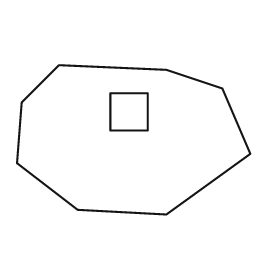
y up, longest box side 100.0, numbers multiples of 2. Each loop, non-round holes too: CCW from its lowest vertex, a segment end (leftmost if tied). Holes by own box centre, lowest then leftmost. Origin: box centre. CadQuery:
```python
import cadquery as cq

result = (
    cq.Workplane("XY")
    .moveTo(14.0, -32.0)
    .lineTo(50.0, -6.0)
    .lineTo(38.0, 22.0)
    .lineTo(14.0, 30.0)
    .lineTo(-32.0, 32.0)
    .lineTo(-48.0, 16.0)
    .lineTo(-50.0, -10.0)
    .lineTo(-24.0, -30.0)
    .close()
    .moveTo(-10.0, 4.0)
    .lineTo(6.0, 4.0)
    .lineTo(6.0, 20.0)
    .lineTo(-10.0, 20.0)
    .close()
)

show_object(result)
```